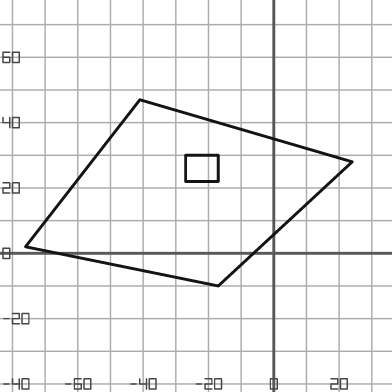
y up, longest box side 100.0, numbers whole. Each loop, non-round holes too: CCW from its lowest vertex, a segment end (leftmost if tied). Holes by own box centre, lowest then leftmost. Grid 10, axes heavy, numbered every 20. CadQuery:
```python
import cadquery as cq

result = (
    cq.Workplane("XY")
    .moveTo(-17.0, -10.0)
    .lineTo(24.0, 28.0)
    .lineTo(-41.0, 47.0)
    .lineTo(-76.0, 2.0)
    .close()
    .moveTo(-27.0, 22.0)
    .lineTo(-17.0, 22.0)
    .lineTo(-17.0, 30.0)
    .lineTo(-27.0, 30.0)
    .close()
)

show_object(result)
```